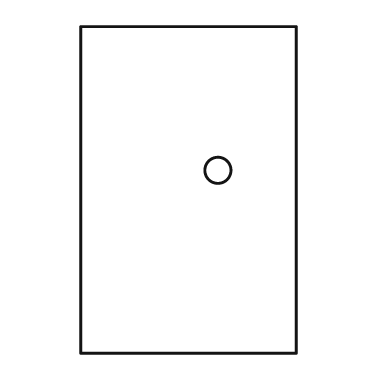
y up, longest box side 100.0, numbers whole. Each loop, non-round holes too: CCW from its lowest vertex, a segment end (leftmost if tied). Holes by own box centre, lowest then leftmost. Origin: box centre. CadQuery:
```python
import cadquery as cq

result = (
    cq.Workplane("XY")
    .moveTo(-33.0, -50.0)
    .lineTo(33.0, -50.0)
    .lineTo(33.0, 50.0)
    .lineTo(-33.0, 50.0)
    .close()
    .moveTo(9.0, 6.0)
    .circle(4.0)
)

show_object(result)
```